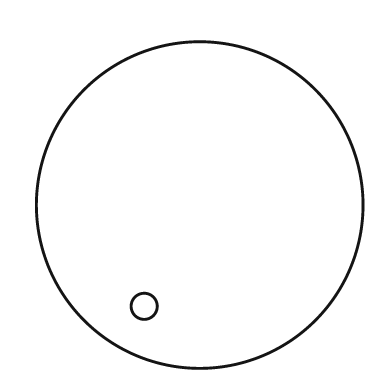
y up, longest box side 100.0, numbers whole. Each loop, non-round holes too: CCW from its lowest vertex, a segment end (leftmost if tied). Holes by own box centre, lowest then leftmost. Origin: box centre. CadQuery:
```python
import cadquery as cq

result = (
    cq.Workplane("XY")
    .moveTo(0.0, 0.0)
    .circle(50.0)
    .moveTo(-17.0, -31.0)
    .circle(4.0)
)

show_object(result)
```